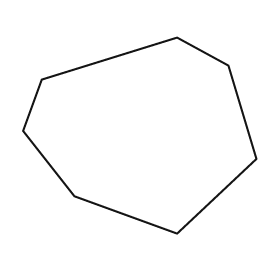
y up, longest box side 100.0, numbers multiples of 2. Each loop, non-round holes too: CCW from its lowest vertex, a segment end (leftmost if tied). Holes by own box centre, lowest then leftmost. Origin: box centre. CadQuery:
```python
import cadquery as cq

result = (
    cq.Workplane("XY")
    .moveTo(16.0, -42.0)
    .lineTo(50.0, -10.0)
    .lineTo(38.0, 30.0)
    .lineTo(16.0, 42.0)
    .lineTo(-42.0, 24.0)
    .lineTo(-50.0, 2.0)
    .lineTo(-28.0, -26.0)
    .close()
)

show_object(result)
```